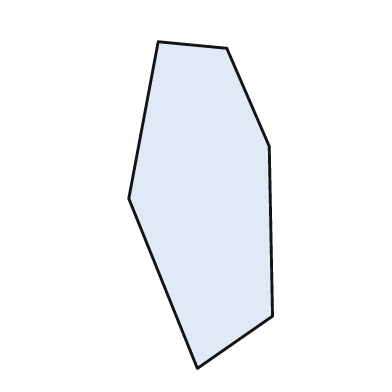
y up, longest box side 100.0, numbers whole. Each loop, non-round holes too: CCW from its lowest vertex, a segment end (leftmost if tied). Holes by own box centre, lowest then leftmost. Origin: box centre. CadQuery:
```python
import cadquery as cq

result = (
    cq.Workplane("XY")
    .moveTo(-1.0, -50.0)
    .lineTo(22.0, -34.0)
    .lineTo(21.0, 18.0)
    .lineTo(8.0, 48.0)
    .lineTo(-13.0, 50.0)
    .lineTo(-22.0, 2.0)
    .close()
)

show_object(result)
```